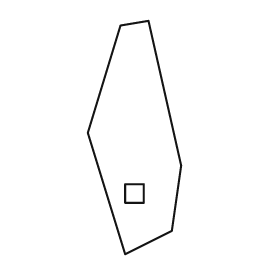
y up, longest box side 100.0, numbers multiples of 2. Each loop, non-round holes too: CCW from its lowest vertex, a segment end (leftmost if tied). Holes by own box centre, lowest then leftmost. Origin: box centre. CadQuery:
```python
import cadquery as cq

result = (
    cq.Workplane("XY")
    .moveTo(-4.0, -50.0)
    .lineTo(16.0, -40.0)
    .lineTo(20.0, -12.0)
    .lineTo(6.0, 50.0)
    .lineTo(-6.0, 48.0)
    .lineTo(-20.0, 2.0)
    .close()
    .moveTo(-4.0, -28.0)
    .lineTo(4.0, -28.0)
    .lineTo(4.0, -20.0)
    .lineTo(-4.0, -20.0)
    .close()
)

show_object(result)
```